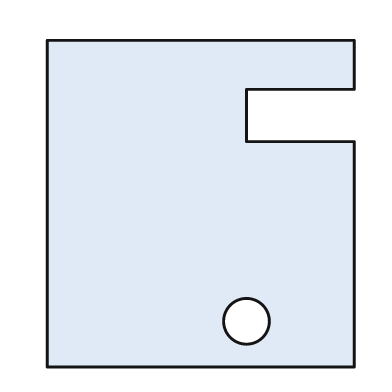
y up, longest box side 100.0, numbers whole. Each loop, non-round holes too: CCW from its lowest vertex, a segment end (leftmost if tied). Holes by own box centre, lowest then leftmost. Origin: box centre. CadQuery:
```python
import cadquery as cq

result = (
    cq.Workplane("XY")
    .moveTo(-47.0, -50.0)
    .lineTo(47.0, -50.0)
    .lineTo(47.0, 19.0)
    .lineTo(14.0, 19.0)
    .lineTo(14.0, 35.0)
    .lineTo(47.0, 35.0)
    .lineTo(47.0, 50.0)
    .lineTo(-47.0, 50.0)
    .close()
    .moveTo(14.0, -36.0)
    .circle(7.0)
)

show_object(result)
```